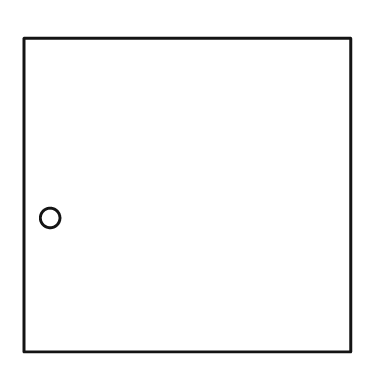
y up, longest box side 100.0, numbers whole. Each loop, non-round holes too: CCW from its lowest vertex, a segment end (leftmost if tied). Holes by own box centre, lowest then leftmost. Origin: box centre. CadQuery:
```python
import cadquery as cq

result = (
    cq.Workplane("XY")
    .moveTo(-50.0, -48.0)
    .lineTo(50.0, -48.0)
    .lineTo(50.0, 48.0)
    .lineTo(-50.0, 48.0)
    .close()
    .moveTo(-42.0, -7.0)
    .circle(3.0)
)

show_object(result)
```